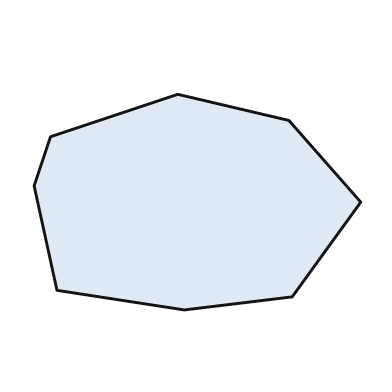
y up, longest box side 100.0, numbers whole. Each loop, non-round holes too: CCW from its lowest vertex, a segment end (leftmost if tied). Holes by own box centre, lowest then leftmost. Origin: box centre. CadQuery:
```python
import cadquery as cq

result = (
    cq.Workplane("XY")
    .moveTo(-4.0, -33.0)
    .lineTo(29.0, -29.0)
    .lineTo(50.0, 0.0)
    .lineTo(28.0, 25.0)
    .lineTo(-6.0, 33.0)
    .lineTo(-45.0, 20.0)
    .lineTo(-50.0, 5.0)
    .lineTo(-43.0, -27.0)
    .close()
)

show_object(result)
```